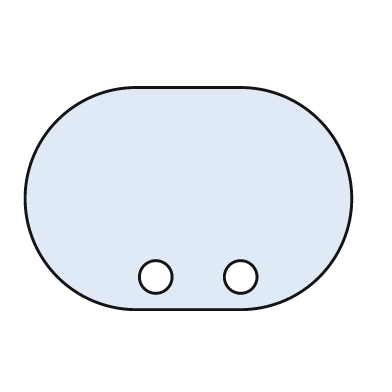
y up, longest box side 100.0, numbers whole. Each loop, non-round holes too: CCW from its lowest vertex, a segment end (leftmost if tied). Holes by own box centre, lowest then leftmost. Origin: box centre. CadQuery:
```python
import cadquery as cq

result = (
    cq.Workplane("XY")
    .moveTo(-16.0, -34.0)
    .lineTo(16.0, -34.0)
    .threePointArc((50.0, 0.0), (16.0, 34.0))
    .lineTo(-16.0, 34.0)
    .threePointArc((-50.0, 0.0), (-16.0, -34.0))
    .close()
    .moveTo(-10.0, -24.0)
    .circle(5.0)
    .moveTo(16.0, -24.0)
    .circle(5.0)
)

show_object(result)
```